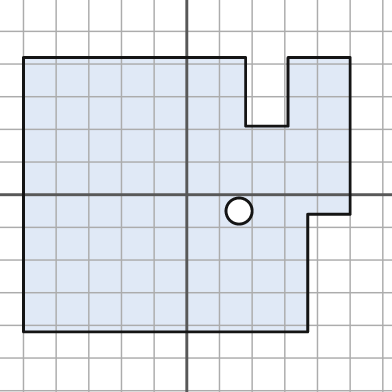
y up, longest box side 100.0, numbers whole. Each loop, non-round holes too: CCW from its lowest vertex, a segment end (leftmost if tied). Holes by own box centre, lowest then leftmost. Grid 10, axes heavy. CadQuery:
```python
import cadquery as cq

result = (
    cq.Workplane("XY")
    .moveTo(-50.0, -42.0)
    .lineTo(37.0, -42.0)
    .lineTo(37.0, -6.0)
    .lineTo(50.0, -6.0)
    .lineTo(50.0, 42.0)
    .lineTo(31.0, 42.0)
    .lineTo(31.0, 21.0)
    .lineTo(18.0, 21.0)
    .lineTo(18.0, 42.0)
    .lineTo(-50.0, 42.0)
    .close()
    .moveTo(16.0, -5.0)
    .circle(4.0)
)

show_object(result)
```